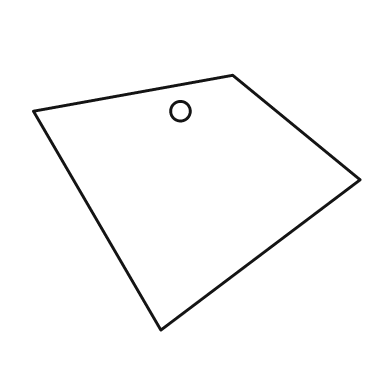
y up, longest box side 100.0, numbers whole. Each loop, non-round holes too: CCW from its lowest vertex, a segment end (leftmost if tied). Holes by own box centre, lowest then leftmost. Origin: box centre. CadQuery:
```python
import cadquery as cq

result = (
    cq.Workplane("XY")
    .moveTo(-11.0, -39.0)
    .lineTo(50.0, 7.0)
    .lineTo(11.0, 39.0)
    .lineTo(-50.0, 28.0)
    .close()
    .moveTo(-5.0, 28.0)
    .circle(3.0)
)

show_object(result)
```